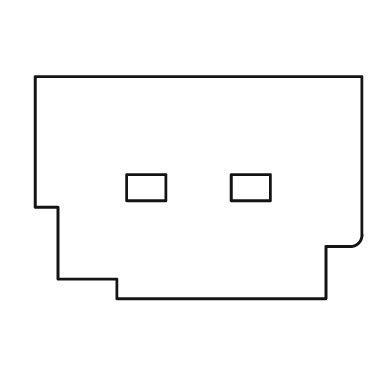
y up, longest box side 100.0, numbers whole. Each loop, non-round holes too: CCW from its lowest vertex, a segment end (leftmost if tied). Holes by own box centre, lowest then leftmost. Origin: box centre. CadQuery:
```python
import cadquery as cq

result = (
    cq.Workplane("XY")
    .moveTo(-25.0, -34.0)
    .lineTo(39.0, -34.0)
    .lineTo(39.0, -18.0)
    .lineTo(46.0, -18.0)
    .threePointArc((49.0, -17.0), (50.0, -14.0))
    .lineTo(50.0, 34.0)
    .lineTo(-50.0, 34.0)
    .lineTo(-50.0, -6.0)
    .lineTo(-43.0, -6.0)
    .lineTo(-43.0, -28.0)
    .lineTo(-25.0, -28.0)
    .close()
    .moveTo(-22.0, -4.0)
    .lineTo(-10.0, -4.0)
    .lineTo(-10.0, 4.0)
    .lineTo(-22.0, 4.0)
    .close()
    .moveTo(10.0, -4.0)
    .lineTo(22.0, -4.0)
    .lineTo(22.0, 4.0)
    .lineTo(10.0, 4.0)
    .close()
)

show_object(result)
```